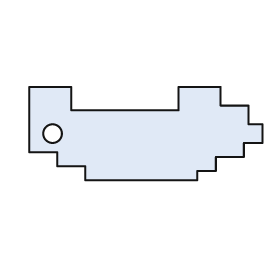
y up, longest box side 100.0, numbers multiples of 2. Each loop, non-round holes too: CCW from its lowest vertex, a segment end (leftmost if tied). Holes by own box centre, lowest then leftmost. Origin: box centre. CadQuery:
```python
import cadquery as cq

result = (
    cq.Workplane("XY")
    .moveTo(-26.0, -20.0)
    .lineTo(22.0, -20.0)
    .lineTo(22.0, -16.0)
    .lineTo(30.0, -16.0)
    .lineTo(30.0, -10.0)
    .lineTo(42.0, -10.0)
    .lineTo(42.0, -4.0)
    .lineTo(50.0, -4.0)
    .lineTo(50.0, 4.0)
    .lineTo(44.0, 4.0)
    .lineTo(44.0, 12.0)
    .lineTo(32.0, 12.0)
    .lineTo(32.0, 20.0)
    .lineTo(14.0, 20.0)
    .lineTo(14.0, 10.0)
    .lineTo(-32.0, 10.0)
    .lineTo(-32.0, 20.0)
    .lineTo(-50.0, 20.0)
    .lineTo(-50.0, -8.0)
    .lineTo(-38.0, -8.0)
    .lineTo(-38.0, -14.0)
    .lineTo(-26.0, -14.0)
    .close()
    .moveTo(-40.0, 0.0)
    .circle(4.0)
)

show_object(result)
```